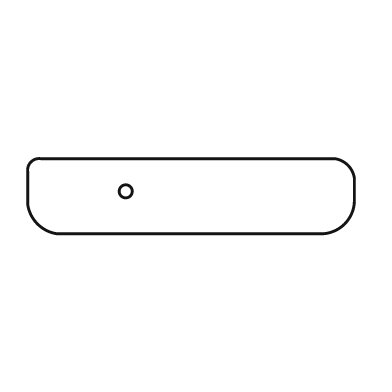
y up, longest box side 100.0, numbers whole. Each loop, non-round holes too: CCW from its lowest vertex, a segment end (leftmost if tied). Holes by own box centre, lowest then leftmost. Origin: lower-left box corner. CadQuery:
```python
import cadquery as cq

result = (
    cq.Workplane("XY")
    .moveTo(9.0, 0.0)
    .lineTo(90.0, 0.0)
    .threePointArc((97.0, 3.0), (100.0, 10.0))
    .lineTo(100.0, 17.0)
    .threePointArc((98.0, 21.0), (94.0, 23.0))
    .lineTo(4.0, 23.0)
    .threePointArc((1.0, 22.0), (0.0, 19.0))
    .lineTo(0.0, 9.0)
    .threePointArc((3.0, 3.0), (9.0, 0.0))
    .close()
    .moveTo(30.0, 13.0)
    .circle(2.0)
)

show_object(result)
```